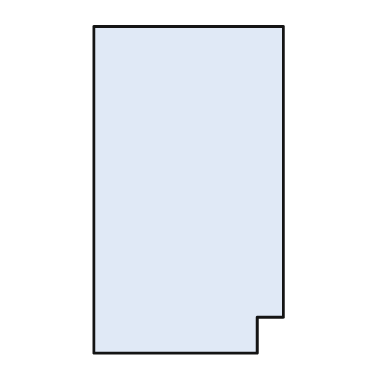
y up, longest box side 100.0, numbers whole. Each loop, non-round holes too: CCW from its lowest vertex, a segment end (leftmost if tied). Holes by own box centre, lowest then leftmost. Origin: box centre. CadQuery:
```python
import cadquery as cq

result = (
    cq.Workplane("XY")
    .moveTo(-29.0, -50.0)
    .lineTo(21.0, -50.0)
    .lineTo(21.0, -39.0)
    .lineTo(29.0, -39.0)
    .lineTo(29.0, 50.0)
    .lineTo(-29.0, 50.0)
    .close()
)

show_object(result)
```